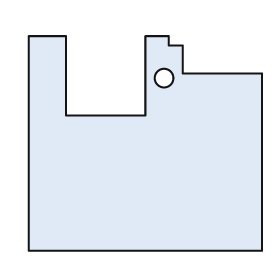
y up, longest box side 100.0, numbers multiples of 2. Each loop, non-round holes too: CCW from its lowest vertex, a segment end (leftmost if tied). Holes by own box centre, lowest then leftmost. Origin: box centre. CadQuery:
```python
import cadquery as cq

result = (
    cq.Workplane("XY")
    .moveTo(-50.0, -46.0)
    .lineTo(50.0, -46.0)
    .lineTo(50.0, 30.0)
    .lineTo(16.0, 30.0)
    .lineTo(16.0, 42.0)
    .lineTo(10.0, 42.0)
    .lineTo(10.0, 46.0)
    .lineTo(0.0, 46.0)
    .lineTo(0.0, 12.0)
    .lineTo(-34.0, 12.0)
    .lineTo(-34.0, 46.0)
    .lineTo(-50.0, 46.0)
    .close()
    .moveTo(8.0, 28.0)
    .circle(4.0)
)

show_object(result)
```